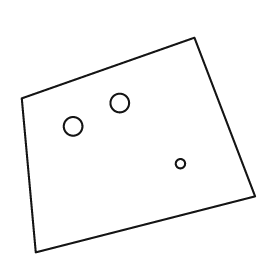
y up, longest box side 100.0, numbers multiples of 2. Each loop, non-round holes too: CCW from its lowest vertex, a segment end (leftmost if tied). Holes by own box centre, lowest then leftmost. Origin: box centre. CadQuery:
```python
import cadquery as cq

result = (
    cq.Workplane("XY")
    .moveTo(-44.0, -46.0)
    .lineTo(50.0, -22.0)
    .lineTo(24.0, 46.0)
    .lineTo(-50.0, 20.0)
    .close()
    .moveTo(18.0, -8.0)
    .circle(2.0)
    .moveTo(-28.0, 8.0)
    .circle(4.0)
    .moveTo(-8.0, 18.0)
    .circle(4.0)
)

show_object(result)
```